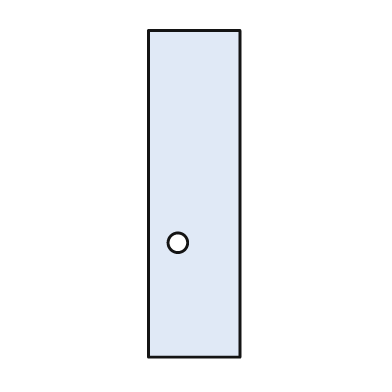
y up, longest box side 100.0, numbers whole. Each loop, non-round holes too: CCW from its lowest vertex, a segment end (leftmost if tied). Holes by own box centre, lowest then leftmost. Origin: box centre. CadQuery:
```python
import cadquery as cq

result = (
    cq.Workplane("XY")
    .moveTo(-14.0, -50.0)
    .lineTo(14.0, -50.0)
    .lineTo(14.0, 50.0)
    .lineTo(-14.0, 50.0)
    .close()
    .moveTo(-5.0, -15.0)
    .circle(3.0)
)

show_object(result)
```